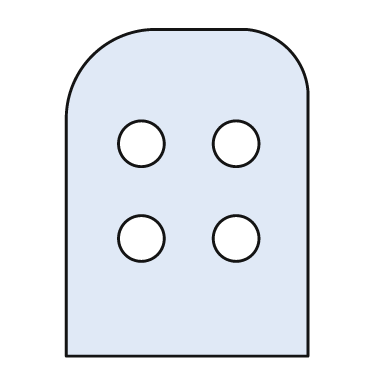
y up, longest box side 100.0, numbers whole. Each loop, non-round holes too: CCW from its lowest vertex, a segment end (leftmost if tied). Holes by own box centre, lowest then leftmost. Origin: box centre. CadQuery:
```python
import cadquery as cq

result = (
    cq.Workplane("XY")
    .moveTo(-37.0, -50.0)
    .lineTo(37.0, -50.0)
    .lineTo(37.0, 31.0)
    .threePointArc((31.0, 44.0), (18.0, 50.0))
    .lineTo(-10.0, 50.0)
    .threePointArc((-29.0, 42.0), (-37.0, 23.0))
    .close()
    .moveTo(-14.0, -14.0)
    .circle(7.0)
    .moveTo(15.0, -14.0)
    .circle(7.0)
    .moveTo(-14.0, 15.0)
    .circle(7.0)
    .moveTo(15.0, 15.0)
    .circle(7.0)
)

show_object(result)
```